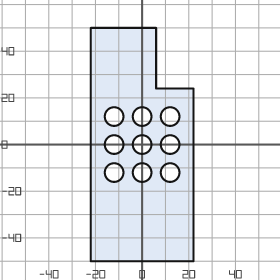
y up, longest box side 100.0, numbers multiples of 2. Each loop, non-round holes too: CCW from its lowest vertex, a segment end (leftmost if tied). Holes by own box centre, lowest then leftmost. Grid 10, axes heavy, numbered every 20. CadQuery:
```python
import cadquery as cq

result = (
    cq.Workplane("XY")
    .moveTo(-22.0, -50.0)
    .lineTo(22.0, -50.0)
    .lineTo(22.0, 24.0)
    .lineTo(6.0, 24.0)
    .lineTo(6.0, 50.0)
    .lineTo(-22.0, 50.0)
    .close()
    .moveTo(-12.0, -12.0)
    .circle(4.0)
    .moveTo(0.0, -12.0)
    .circle(4.0)
    .moveTo(12.0, -12.0)
    .circle(4.0)
    .moveTo(-12.0, 0.0)
    .circle(4.0)
    .moveTo(0.0, 0.0)
    .circle(4.0)
    .moveTo(12.0, 0.0)
    .circle(4.0)
    .moveTo(-12.0, 12.0)
    .circle(4.0)
    .moveTo(0.0, 12.0)
    .circle(4.0)
    .moveTo(12.0, 12.0)
    .circle(4.0)
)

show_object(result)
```